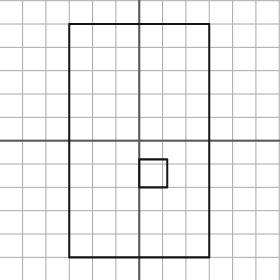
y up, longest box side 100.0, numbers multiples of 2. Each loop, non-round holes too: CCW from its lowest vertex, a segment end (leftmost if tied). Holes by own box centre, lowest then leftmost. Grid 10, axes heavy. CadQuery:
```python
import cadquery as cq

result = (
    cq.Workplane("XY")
    .moveTo(-30.0, -50.0)
    .lineTo(30.0, -50.0)
    .lineTo(30.0, 50.0)
    .lineTo(-30.0, 50.0)
    .close()
    .moveTo(0.0, -20.0)
    .lineTo(12.0, -20.0)
    .lineTo(12.0, -8.0)
    .lineTo(0.0, -8.0)
    .close()
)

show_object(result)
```